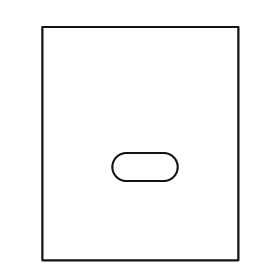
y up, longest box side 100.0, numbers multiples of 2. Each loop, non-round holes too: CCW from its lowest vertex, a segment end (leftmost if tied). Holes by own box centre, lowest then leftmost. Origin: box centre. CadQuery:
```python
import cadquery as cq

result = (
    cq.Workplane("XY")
    .moveTo(-42.0, -50.0)
    .lineTo(42.0, -50.0)
    .lineTo(42.0, 50.0)
    .lineTo(-42.0, 50.0)
    .close()
    .moveTo(-6.0, -16.0)
    .lineTo(10.0, -16.0)
    .threePointArc((16.0, -10.0), (10.0, -4.0))
    .lineTo(-6.0, -4.0)
    .threePointArc((-12.0, -10.0), (-6.0, -16.0))
    .close()
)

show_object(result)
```